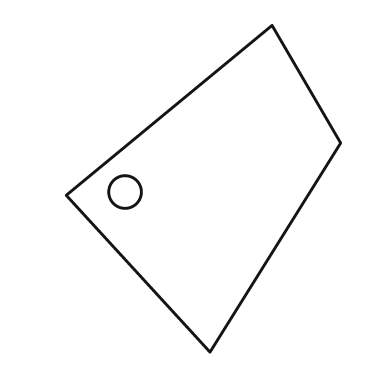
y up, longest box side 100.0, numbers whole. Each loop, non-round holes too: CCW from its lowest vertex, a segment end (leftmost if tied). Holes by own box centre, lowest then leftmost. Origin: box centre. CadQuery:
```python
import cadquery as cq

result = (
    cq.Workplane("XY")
    .moveTo(2.0, -50.0)
    .lineTo(42.0, 14.0)
    .lineTo(21.0, 50.0)
    .lineTo(-42.0, -2.0)
    .close()
    .moveTo(-24.0, -1.0)
    .circle(5.0)
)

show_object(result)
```